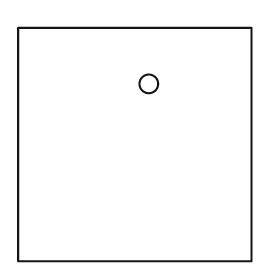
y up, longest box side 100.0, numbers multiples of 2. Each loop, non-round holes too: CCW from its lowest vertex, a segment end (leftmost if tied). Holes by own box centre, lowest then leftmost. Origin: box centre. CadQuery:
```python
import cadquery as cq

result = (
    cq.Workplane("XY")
    .moveTo(-50.0, -50.0)
    .lineTo(50.0, -50.0)
    .lineTo(50.0, 50.0)
    .lineTo(-50.0, 50.0)
    .close()
    .moveTo(6.0, 26.0)
    .circle(4.0)
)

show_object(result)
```